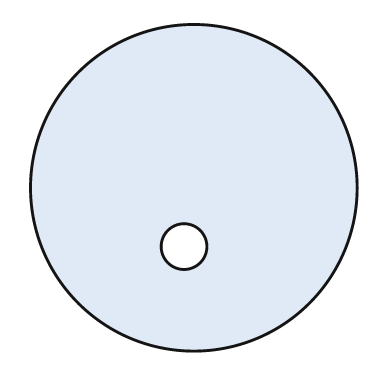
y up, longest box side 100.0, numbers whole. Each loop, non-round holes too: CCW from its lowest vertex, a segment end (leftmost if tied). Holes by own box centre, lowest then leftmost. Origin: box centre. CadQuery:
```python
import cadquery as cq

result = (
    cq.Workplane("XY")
    .moveTo(0.0, 0.0)
    .circle(50.0)
    .moveTo(-3.0, -18.0)
    .circle(7.0)
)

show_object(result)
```